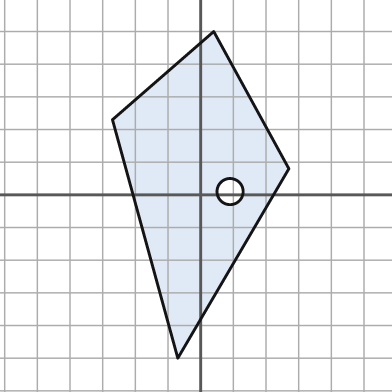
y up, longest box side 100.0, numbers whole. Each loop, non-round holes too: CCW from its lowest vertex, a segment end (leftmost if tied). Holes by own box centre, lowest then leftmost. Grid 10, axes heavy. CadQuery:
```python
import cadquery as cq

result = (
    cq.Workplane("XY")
    .moveTo(-7.0, -50.0)
    .lineTo(27.0, 8.0)
    .lineTo(4.0, 50.0)
    .lineTo(-27.0, 23.0)
    .close()
    .moveTo(9.0, 1.0)
    .circle(4.0)
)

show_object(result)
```